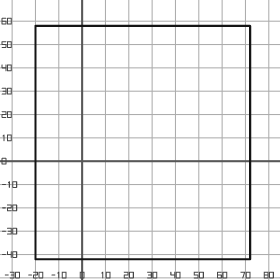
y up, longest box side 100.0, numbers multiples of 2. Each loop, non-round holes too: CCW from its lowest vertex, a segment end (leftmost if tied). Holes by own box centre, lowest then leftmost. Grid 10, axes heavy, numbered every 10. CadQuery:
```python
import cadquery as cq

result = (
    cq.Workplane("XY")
    .moveTo(-20.0, -42.0)
    .lineTo(72.0, -42.0)
    .lineTo(72.0, 58.0)
    .lineTo(-20.0, 58.0)
    .close()
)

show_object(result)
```